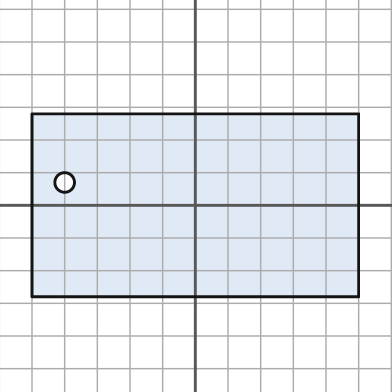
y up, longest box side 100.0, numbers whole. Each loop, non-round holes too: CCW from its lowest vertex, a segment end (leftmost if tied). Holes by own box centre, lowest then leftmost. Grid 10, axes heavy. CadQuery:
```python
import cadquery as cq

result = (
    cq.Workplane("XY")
    .moveTo(-50.0, -28.0)
    .lineTo(50.0, -28.0)
    .lineTo(50.0, 28.0)
    .lineTo(-50.0, 28.0)
    .close()
    .moveTo(-40.0, 7.0)
    .circle(3.0)
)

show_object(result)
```